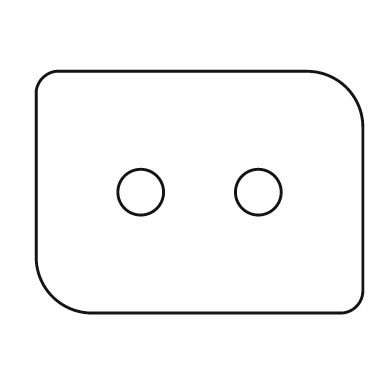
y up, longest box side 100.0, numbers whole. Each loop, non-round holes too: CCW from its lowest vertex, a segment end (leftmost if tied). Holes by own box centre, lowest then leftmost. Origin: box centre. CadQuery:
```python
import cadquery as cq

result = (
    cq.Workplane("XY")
    .moveTo(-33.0, -37.0)
    .lineTo(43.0, -37.0)
    .threePointArc((48.0, -35.0), (50.0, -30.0))
    .lineTo(50.0, 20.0)
    .threePointArc((45.0, 32.0), (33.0, 37.0))
    .lineTo(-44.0, 37.0)
    .threePointArc((-48.0, 35.0), (-50.0, 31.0))
    .lineTo(-50.0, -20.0)
    .threePointArc((-45.0, -32.0), (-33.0, -37.0))
    .close()
    .moveTo(-18.0, 0.0)
    .circle(7.0)
    .moveTo(18.0, 0.0)
    .circle(7.0)
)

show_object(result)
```